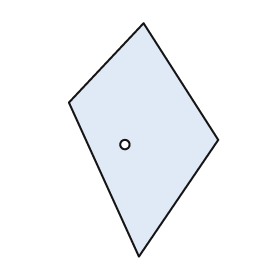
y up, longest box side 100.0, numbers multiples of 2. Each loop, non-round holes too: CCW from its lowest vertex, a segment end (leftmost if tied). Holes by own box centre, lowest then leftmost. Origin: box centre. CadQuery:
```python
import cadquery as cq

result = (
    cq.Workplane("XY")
    .moveTo(-2.0, -50.0)
    .lineTo(32.0, 0.0)
    .lineTo(0.0, 50.0)
    .lineTo(-32.0, 16.0)
    .close()
    .moveTo(-8.0, -2.0)
    .circle(2.0)
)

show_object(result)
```